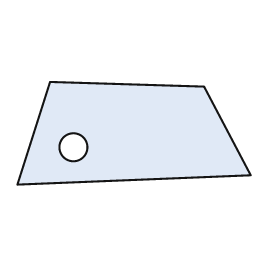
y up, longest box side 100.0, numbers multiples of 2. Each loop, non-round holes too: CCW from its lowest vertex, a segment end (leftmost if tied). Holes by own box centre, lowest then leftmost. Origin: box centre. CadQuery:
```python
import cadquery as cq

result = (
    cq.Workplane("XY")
    .moveTo(-50.0, -22.0)
    .lineTo(50.0, -18.0)
    .lineTo(30.0, 20.0)
    .lineTo(-36.0, 22.0)
    .close()
    .moveTo(-26.0, -6.0)
    .circle(6.0)
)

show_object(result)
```